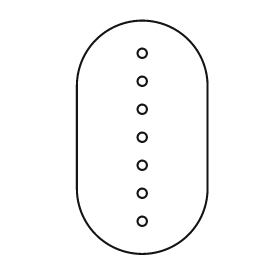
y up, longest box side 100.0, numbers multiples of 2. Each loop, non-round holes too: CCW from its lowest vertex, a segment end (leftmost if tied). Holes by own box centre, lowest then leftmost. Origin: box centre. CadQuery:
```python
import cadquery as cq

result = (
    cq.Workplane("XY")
    .moveTo(-28.0, -22.0)
    .threePointArc((0.0, -50.0), (28.0, -22.0))
    .lineTo(28.0, 22.0)
    .threePointArc((0.0, 50.0), (-28.0, 22.0))
    .close()
    .moveTo(0.0, -36.0)
    .circle(2.0)
    .moveTo(0.0, -24.0)
    .circle(2.0)
    .moveTo(0.0, -12.0)
    .circle(2.0)
    .moveTo(0.0, 0.0)
    .circle(2.0)
    .moveTo(0.0, 12.0)
    .circle(2.0)
    .moveTo(0.0, 24.0)
    .circle(2.0)
    .moveTo(0.0, 36.0)
    .circle(2.0)
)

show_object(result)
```